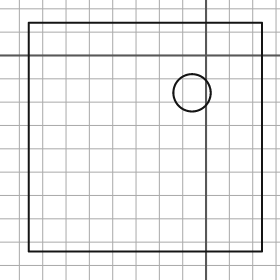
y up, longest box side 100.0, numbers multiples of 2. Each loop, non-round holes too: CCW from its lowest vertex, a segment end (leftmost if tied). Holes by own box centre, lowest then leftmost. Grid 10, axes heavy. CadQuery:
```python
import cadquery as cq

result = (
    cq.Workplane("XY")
    .moveTo(-76.0, -84.0)
    .lineTo(24.0, -84.0)
    .lineTo(24.0, 14.0)
    .lineTo(-76.0, 14.0)
    .close()
    .moveTo(-6.0, -16.0)
    .circle(8.0)
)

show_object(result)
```